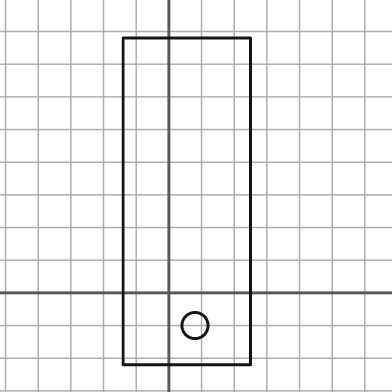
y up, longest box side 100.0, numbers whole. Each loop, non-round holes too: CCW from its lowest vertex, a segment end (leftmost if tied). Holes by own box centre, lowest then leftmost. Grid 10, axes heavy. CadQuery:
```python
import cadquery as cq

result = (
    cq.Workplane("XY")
    .moveTo(-14.0, -22.0)
    .lineTo(25.0, -22.0)
    .lineTo(25.0, 78.0)
    .lineTo(-14.0, 78.0)
    .close()
    .moveTo(8.0, -10.0)
    .circle(4.0)
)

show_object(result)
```